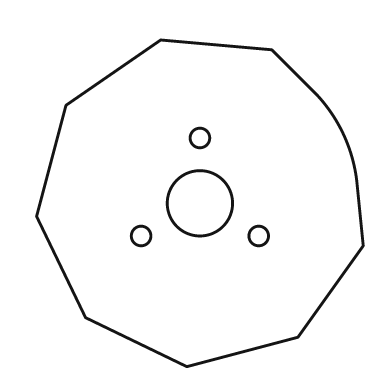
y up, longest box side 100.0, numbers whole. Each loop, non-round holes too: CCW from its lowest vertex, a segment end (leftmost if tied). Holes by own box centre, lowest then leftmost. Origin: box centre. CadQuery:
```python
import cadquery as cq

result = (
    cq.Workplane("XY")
    .moveTo(-4.0, -50.0)
    .lineTo(30.0, -41.0)
    .lineTo(50.0, -13.0)
    .lineTo(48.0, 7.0)
    .threePointArc((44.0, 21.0), (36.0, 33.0))
    .lineTo(22.0, 47.0)
    .lineTo(-12.0, 50.0)
    .lineTo(-41.0, 30.0)
    .lineTo(-50.0, -4.0)
    .lineTo(-35.0, -35.0)
    .close()
    .moveTo(-18.0, -10.0)
    .circle(3.0)
    .moveTo(18.0, -10.0)
    .circle(3.0)
    .moveTo(0.0, 0.0)
    .circle(10.0)
    .moveTo(0.0, 20.0)
    .circle(3.0)
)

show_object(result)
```